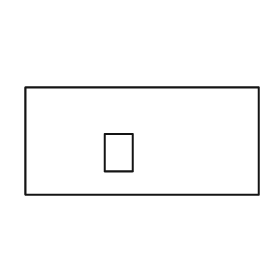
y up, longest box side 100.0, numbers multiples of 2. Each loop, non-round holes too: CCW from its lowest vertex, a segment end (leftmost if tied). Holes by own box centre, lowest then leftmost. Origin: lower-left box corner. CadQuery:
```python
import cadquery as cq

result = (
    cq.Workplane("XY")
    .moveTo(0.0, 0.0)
    .lineTo(100.0, 0.0)
    .lineTo(100.0, 46.0)
    .lineTo(0.0, 46.0)
    .close()
    .moveTo(34.0, 10.0)
    .lineTo(46.0, 10.0)
    .lineTo(46.0, 26.0)
    .lineTo(34.0, 26.0)
    .close()
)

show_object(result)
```